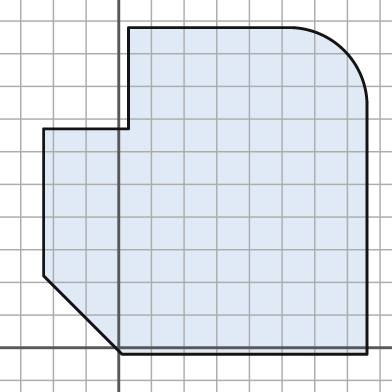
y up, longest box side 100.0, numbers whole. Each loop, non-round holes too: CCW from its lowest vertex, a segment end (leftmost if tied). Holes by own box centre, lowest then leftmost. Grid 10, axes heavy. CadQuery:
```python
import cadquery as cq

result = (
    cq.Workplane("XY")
    .moveTo(1.0, -2.0)
    .lineTo(76.0, -2.0)
    .lineTo(76.0, 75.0)
    .threePointArc((69.0, 91.0), (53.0, 98.0))
    .lineTo(3.0, 98.0)
    .lineTo(3.0, 67.0)
    .lineTo(-23.0, 67.0)
    .lineTo(-23.0, 22.0)
    .close()
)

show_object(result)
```